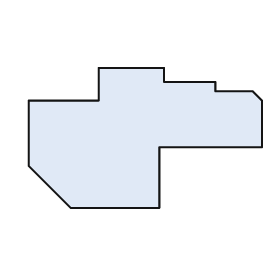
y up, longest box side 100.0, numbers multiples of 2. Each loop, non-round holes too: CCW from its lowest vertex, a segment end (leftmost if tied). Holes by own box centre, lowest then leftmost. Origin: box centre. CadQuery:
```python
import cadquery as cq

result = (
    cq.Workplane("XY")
    .moveTo(-32.0, -30.0)
    .lineTo(6.0, -30.0)
    .lineTo(6.0, -4.0)
    .lineTo(50.0, -4.0)
    .lineTo(50.0, 16.0)
    .lineTo(46.0, 20.0)
    .lineTo(30.0, 20.0)
    .lineTo(30.0, 24.0)
    .lineTo(8.0, 24.0)
    .lineTo(8.0, 30.0)
    .lineTo(-20.0, 30.0)
    .lineTo(-20.0, 16.0)
    .lineTo(-50.0, 16.0)
    .lineTo(-50.0, -12.0)
    .close()
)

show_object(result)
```